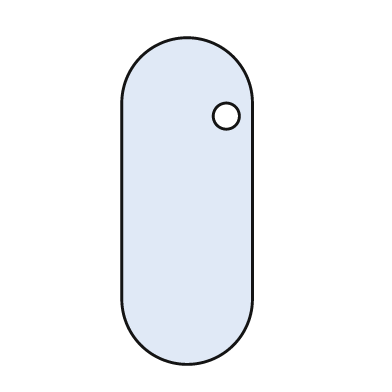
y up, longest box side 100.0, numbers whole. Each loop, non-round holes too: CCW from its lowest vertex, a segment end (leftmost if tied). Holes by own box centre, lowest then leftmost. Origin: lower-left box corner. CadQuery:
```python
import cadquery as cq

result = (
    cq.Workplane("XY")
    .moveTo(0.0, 20.0)
    .threePointArc((20.0, 0.0), (40.0, 20.0))
    .lineTo(40.0, 80.0)
    .threePointArc((20.0, 100.0), (0.0, 80.0))
    .close()
    .moveTo(32.0, 76.0)
    .circle(4.0)
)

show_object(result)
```